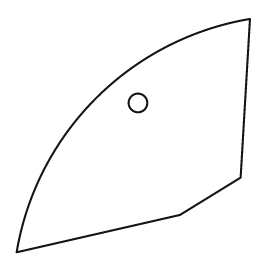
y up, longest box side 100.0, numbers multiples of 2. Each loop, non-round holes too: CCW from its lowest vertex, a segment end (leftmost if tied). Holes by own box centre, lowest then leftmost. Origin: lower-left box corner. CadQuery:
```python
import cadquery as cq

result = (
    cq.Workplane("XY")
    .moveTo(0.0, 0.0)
    .lineTo(70.0, 16.0)
    .lineTo(96.0, 32.0)
    .lineTo(100.0, 100.0)
    .threePointArc((34.0, 66.0), (0.0, 0.0))
    .close()
    .moveTo(52.0, 64.0)
    .circle(4.0)
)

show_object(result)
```